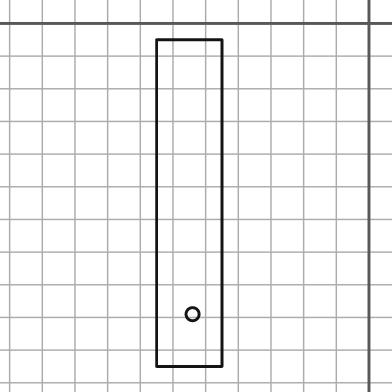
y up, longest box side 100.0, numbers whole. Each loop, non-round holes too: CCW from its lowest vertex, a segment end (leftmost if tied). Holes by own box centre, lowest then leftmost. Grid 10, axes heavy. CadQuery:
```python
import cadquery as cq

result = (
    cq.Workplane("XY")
    .moveTo(-65.0, -105.0)
    .lineTo(-45.0, -105.0)
    .lineTo(-45.0, -5.0)
    .lineTo(-65.0, -5.0)
    .close()
    .moveTo(-54.0, -89.0)
    .circle(2.0)
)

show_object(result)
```